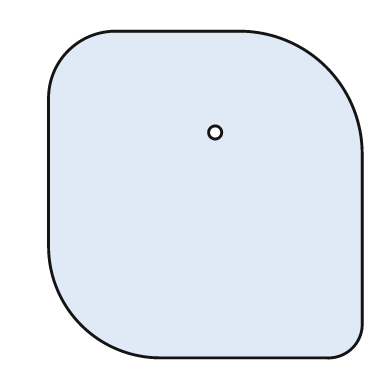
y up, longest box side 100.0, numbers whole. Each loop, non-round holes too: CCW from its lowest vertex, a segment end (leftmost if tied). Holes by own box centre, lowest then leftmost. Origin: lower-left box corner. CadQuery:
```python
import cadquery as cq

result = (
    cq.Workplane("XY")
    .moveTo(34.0, 0.0)
    .lineTo(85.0, 0.0)
    .threePointArc((93.0, 3.0), (96.0, 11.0))
    .lineTo(96.0, 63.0)
    .threePointArc((85.0, 89.0), (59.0, 100.0))
    .lineTo(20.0, 100.0)
    .threePointArc((6.0, 94.0), (0.0, 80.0))
    .lineTo(0.0, 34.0)
    .threePointArc((10.0, 10.0), (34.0, 0.0))
    .close()
    .moveTo(51.0, 69.0)
    .circle(2.0)
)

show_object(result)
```